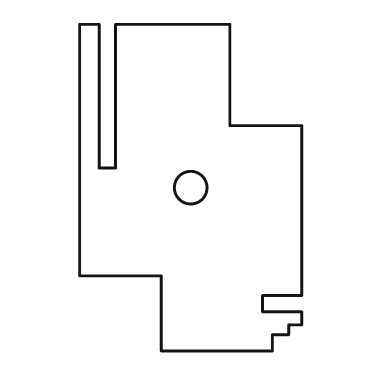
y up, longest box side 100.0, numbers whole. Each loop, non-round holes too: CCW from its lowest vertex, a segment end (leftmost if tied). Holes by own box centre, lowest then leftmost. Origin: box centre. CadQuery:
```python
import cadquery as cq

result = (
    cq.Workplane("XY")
    .moveTo(-9.0, -50.0)
    .lineTo(25.0, -50.0)
    .lineTo(25.0, -45.0)
    .lineTo(30.0, -45.0)
    .lineTo(30.0, -42.0)
    .lineTo(34.0, -42.0)
    .lineTo(34.0, -38.0)
    .lineTo(22.0, -38.0)
    .lineTo(22.0, -33.0)
    .lineTo(34.0, -33.0)
    .lineTo(34.0, 19.0)
    .lineTo(12.0, 19.0)
    .lineTo(12.0, 50.0)
    .lineTo(-23.0, 50.0)
    .lineTo(-23.0, 6.0)
    .lineTo(-28.0, 6.0)
    .lineTo(-28.0, 50.0)
    .lineTo(-34.0, 50.0)
    .lineTo(-34.0, -27.0)
    .lineTo(-9.0, -27.0)
    .close()
    .moveTo(0.0, 0.0)
    .circle(5.0)
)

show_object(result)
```